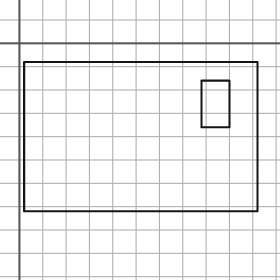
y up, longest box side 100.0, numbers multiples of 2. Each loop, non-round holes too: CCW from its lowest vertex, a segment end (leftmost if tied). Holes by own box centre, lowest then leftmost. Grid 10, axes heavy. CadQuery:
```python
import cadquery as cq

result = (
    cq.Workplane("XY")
    .moveTo(2.0, -72.0)
    .lineTo(102.0, -72.0)
    .lineTo(102.0, -8.0)
    .lineTo(2.0, -8.0)
    .close()
    .moveTo(78.0, -36.0)
    .lineTo(90.0, -36.0)
    .lineTo(90.0, -16.0)
    .lineTo(78.0, -16.0)
    .close()
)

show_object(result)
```